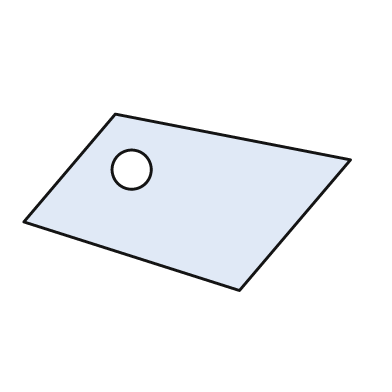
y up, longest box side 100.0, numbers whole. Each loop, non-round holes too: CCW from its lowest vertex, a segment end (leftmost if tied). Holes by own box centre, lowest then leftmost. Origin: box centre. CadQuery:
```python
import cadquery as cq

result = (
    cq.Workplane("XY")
    .moveTo(16.0, -27.0)
    .lineTo(50.0, 13.0)
    .lineTo(-22.0, 27.0)
    .lineTo(-50.0, -6.0)
    .close()
    .moveTo(-17.0, 10.0)
    .circle(6.0)
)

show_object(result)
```